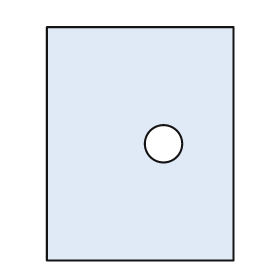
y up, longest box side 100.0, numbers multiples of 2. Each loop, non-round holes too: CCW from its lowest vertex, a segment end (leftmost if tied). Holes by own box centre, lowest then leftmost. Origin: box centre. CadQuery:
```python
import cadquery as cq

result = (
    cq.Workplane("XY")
    .moveTo(-40.0, -50.0)
    .lineTo(40.0, -50.0)
    .lineTo(40.0, 50.0)
    .lineTo(-40.0, 50.0)
    .close()
    .moveTo(10.0, 0.0)
    .circle(8.0)
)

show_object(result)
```